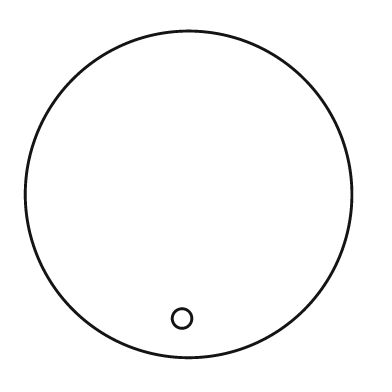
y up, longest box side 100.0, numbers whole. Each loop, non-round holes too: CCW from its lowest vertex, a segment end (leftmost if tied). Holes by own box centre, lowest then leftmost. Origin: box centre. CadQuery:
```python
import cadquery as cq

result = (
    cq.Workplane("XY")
    .moveTo(0.0, 0.0)
    .circle(50.0)
    .moveTo(-2.0, -38.0)
    .circle(3.0)
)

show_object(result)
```